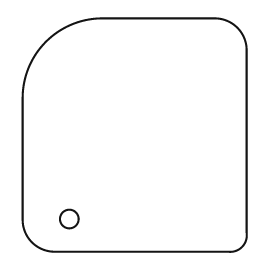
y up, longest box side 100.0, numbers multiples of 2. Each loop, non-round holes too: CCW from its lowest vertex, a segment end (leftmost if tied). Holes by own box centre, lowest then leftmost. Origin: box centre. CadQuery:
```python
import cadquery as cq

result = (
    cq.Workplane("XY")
    .moveTo(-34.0, -50.0)
    .lineTo(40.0, -50.0)
    .threePointArc((46.0, -48.0), (48.0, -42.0))
    .lineTo(48.0, 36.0)
    .threePointArc((44.0, 46.0), (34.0, 50.0))
    .lineTo(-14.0, 50.0)
    .threePointArc((-38.0, 40.0), (-48.0, 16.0))
    .lineTo(-48.0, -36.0)
    .threePointArc((-44.0, -46.0), (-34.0, -50.0))
    .close()
    .moveTo(-28.0, -36.0)
    .circle(4.0)
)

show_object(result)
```